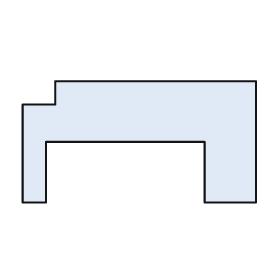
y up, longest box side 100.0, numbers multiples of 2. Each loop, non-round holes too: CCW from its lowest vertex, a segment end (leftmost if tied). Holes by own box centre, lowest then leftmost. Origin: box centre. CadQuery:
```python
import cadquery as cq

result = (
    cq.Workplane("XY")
    .moveTo(-50.0, -26.0)
    .lineTo(-40.0, -26.0)
    .lineTo(-40.0, 0.0)
    .lineTo(28.0, 0.0)
    .lineTo(28.0, -26.0)
    .lineTo(50.0, -26.0)
    .lineTo(50.0, 26.0)
    .lineTo(-36.0, 26.0)
    .lineTo(-36.0, 16.0)
    .lineTo(-50.0, 16.0)
    .close()
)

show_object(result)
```